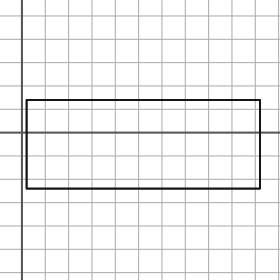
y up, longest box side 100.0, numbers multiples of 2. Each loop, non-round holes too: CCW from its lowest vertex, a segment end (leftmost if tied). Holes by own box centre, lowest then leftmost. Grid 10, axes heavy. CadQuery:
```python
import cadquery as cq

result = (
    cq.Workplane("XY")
    .moveTo(2.0, -24.0)
    .lineTo(102.0, -24.0)
    .lineTo(102.0, 14.0)
    .lineTo(2.0, 14.0)
    .close()
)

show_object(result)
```